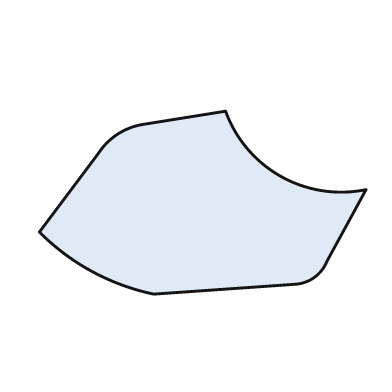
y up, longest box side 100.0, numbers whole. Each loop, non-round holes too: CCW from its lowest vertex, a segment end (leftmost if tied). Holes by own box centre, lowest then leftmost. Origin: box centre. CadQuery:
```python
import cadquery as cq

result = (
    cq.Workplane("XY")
    .moveTo(-15.0, -28.0)
    .lineTo(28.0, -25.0)
    .threePointArc((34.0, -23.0), (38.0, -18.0))
    .lineTo(50.0, 4.0)
    .threePointArc((24.0, 8.0), (7.0, 28.0))
    .lineTo(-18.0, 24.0)
    .threePointArc((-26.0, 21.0), (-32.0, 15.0))
    .lineTo(-50.0, -9.0)
    .threePointArc((-34.0, -21.0), (-15.0, -28.0))
    .close()
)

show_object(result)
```